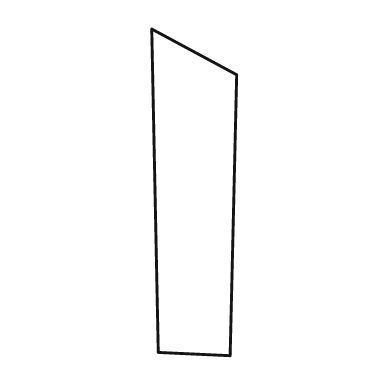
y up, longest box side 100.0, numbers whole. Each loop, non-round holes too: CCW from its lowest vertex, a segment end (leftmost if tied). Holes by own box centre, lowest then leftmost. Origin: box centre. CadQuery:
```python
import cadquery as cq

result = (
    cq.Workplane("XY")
    .moveTo(11.0, -50.0)
    .lineTo(13.0, 36.0)
    .lineTo(-13.0, 50.0)
    .lineTo(-11.0, -49.0)
    .close()
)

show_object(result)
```